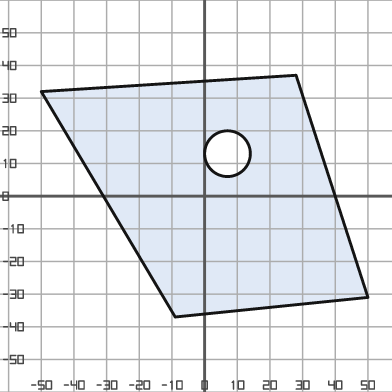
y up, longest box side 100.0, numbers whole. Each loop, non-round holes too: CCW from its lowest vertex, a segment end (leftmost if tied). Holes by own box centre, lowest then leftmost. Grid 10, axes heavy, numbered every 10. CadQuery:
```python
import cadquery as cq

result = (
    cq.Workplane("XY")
    .moveTo(-9.0, -37.0)
    .lineTo(50.0, -31.0)
    .lineTo(28.0, 37.0)
    .lineTo(-50.0, 32.0)
    .close()
    .moveTo(7.0, 13.0)
    .circle(7.0)
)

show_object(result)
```